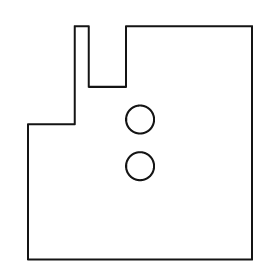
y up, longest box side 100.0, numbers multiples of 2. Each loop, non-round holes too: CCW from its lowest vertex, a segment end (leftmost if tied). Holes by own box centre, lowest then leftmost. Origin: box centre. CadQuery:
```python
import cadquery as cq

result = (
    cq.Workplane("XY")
    .moveTo(-48.0, -50.0)
    .lineTo(48.0, -50.0)
    .lineTo(48.0, 50.0)
    .lineTo(-6.0, 50.0)
    .lineTo(-6.0, 24.0)
    .lineTo(-22.0, 24.0)
    .lineTo(-22.0, 50.0)
    .lineTo(-28.0, 50.0)
    .lineTo(-28.0, 8.0)
    .lineTo(-48.0, 8.0)
    .close()
    .moveTo(0.0, -10.0)
    .circle(6.0)
    .moveTo(0.0, 10.0)
    .circle(6.0)
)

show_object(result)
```